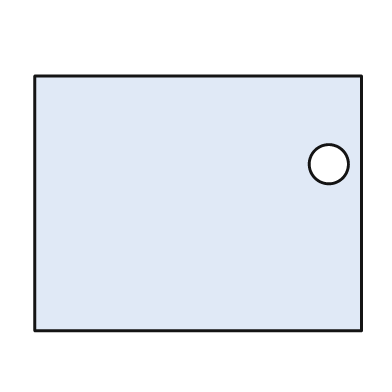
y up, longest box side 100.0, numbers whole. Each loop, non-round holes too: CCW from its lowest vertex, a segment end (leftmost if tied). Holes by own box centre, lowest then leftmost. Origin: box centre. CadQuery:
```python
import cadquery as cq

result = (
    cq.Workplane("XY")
    .moveTo(-50.0, -39.0)
    .lineTo(50.0, -39.0)
    .lineTo(50.0, 39.0)
    .lineTo(-50.0, 39.0)
    .close()
    .moveTo(40.0, 12.0)
    .circle(6.0)
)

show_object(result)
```